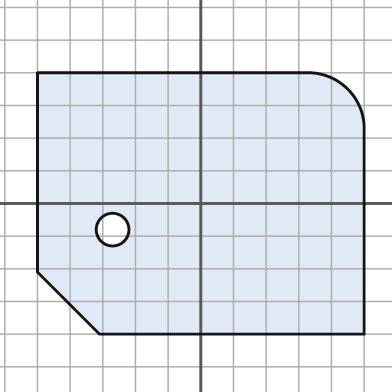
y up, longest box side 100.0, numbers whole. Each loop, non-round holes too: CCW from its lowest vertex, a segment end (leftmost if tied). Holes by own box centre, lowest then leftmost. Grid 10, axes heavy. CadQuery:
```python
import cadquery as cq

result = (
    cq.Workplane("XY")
    .moveTo(-31.0, -40.0)
    .lineTo(50.0, -40.0)
    .lineTo(50.0, 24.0)
    .threePointArc((45.0, 35.0), (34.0, 40.0))
    .lineTo(-50.0, 40.0)
    .lineTo(-50.0, -21.0)
    .close()
    .moveTo(-27.0, -8.0)
    .circle(5.0)
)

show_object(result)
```